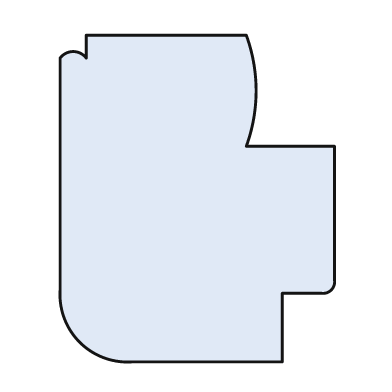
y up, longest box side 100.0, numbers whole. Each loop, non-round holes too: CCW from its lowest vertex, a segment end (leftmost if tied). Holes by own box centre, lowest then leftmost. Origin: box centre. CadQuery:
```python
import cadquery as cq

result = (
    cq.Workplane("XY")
    .moveTo(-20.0, -50.0)
    .lineTo(26.0, -50.0)
    .lineTo(26.0, -29.0)
    .lineTo(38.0, -29.0)
    .threePointArc((41.0, -28.0), (42.0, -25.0))
    .lineTo(42.0, 16.0)
    .lineTo(15.0, 16.0)
    .threePointArc((18.0, 33.0), (15.0, 50.0))
    .lineTo(-34.0, 50.0)
    .lineTo(-34.0, 43.0)
    .threePointArc((-38.0, 45.0), (-42.0, 43.0))
    .lineTo(-42.0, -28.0)
    .threePointArc((-36.0, -44.0), (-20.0, -50.0))
    .close()
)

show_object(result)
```